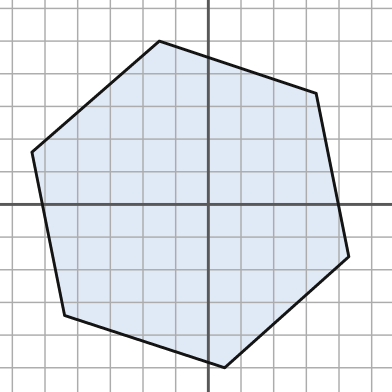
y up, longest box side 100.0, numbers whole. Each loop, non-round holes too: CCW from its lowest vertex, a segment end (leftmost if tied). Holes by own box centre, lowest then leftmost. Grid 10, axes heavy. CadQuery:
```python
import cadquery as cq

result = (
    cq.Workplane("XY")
    .moveTo(5.0, -50.0)
    .lineTo(43.0, -16.0)
    .lineTo(33.0, 34.0)
    .lineTo(-15.0, 50.0)
    .lineTo(-54.0, 16.0)
    .lineTo(-44.0, -34.0)
    .close()
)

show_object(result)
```